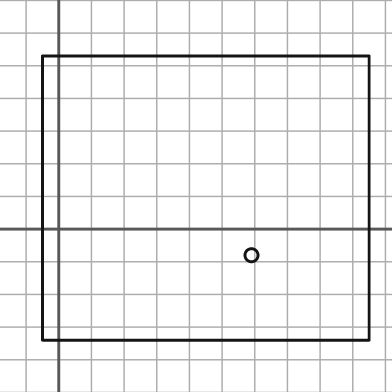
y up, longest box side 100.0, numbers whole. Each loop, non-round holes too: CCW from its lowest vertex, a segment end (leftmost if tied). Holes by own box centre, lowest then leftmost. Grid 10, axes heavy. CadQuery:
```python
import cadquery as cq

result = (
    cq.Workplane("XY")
    .moveTo(-5.0, -34.0)
    .lineTo(95.0, -34.0)
    .lineTo(95.0, 53.0)
    .lineTo(-5.0, 53.0)
    .close()
    .moveTo(59.0, -8.0)
    .circle(2.0)
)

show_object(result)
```